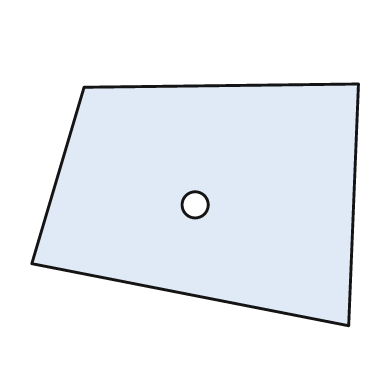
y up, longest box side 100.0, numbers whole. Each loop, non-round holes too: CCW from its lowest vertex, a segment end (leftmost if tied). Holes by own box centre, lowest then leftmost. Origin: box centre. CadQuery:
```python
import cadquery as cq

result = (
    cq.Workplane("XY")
    .moveTo(47.0, -37.0)
    .lineTo(50.0, 37.0)
    .lineTo(-34.0, 36.0)
    .lineTo(-50.0, -18.0)
    .close()
    .moveTo(0.0, 0.0)
    .circle(4.0)
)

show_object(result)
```